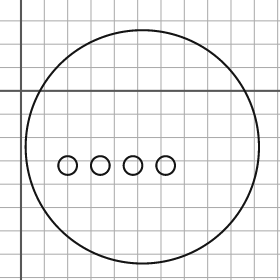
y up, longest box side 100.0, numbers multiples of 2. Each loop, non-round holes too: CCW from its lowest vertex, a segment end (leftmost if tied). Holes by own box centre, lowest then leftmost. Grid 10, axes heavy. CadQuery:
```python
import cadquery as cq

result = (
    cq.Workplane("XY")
    .moveTo(52.0, -24.0)
    .circle(50.0)
    .moveTo(20.0, -32.0)
    .circle(4.0)
    .moveTo(34.0, -32.0)
    .circle(4.0)
    .moveTo(48.0, -32.0)
    .circle(4.0)
    .moveTo(62.0, -32.0)
    .circle(4.0)
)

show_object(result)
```